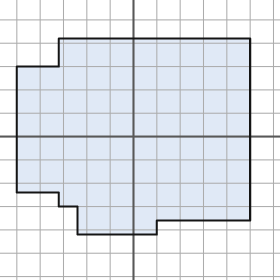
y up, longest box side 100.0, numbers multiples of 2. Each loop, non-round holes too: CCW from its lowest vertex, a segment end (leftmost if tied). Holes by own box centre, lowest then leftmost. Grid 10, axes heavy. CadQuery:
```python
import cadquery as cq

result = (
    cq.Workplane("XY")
    .moveTo(-24.0, -42.0)
    .lineTo(10.0, -42.0)
    .lineTo(10.0, -36.0)
    .lineTo(50.0, -36.0)
    .lineTo(50.0, 42.0)
    .lineTo(-32.0, 42.0)
    .lineTo(-32.0, 30.0)
    .lineTo(-50.0, 30.0)
    .lineTo(-50.0, -24.0)
    .lineTo(-32.0, -24.0)
    .lineTo(-32.0, -30.0)
    .lineTo(-24.0, -30.0)
    .close()
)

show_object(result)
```